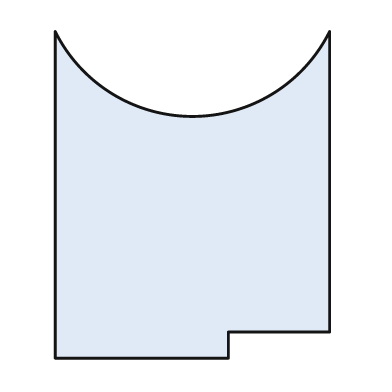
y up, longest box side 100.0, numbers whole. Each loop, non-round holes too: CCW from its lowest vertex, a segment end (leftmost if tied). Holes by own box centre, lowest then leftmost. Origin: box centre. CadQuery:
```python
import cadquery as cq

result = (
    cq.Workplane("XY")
    .moveTo(-42.0, -50.0)
    .lineTo(11.0, -50.0)
    .lineTo(11.0, -42.0)
    .lineTo(42.0, -42.0)
    .lineTo(42.0, 50.0)
    .threePointArc((0.0, 24.0), (-42.0, 50.0))
    .close()
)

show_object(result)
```